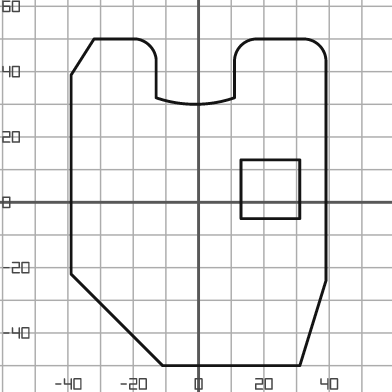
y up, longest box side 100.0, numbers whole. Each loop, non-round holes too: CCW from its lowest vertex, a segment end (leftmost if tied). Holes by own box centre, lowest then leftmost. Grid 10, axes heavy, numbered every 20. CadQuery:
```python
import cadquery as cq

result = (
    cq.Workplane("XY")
    .moveTo(-11.0, -50.0)
    .lineTo(31.0, -50.0)
    .lineTo(39.0, -24.0)
    .lineTo(39.0, 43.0)
    .threePointArc((37.0, 48.0), (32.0, 50.0))
    .lineTo(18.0, 50.0)
    .threePointArc((13.0, 48.0), (11.0, 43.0))
    .lineTo(11.0, 32.0)
    .threePointArc((-1.0, 30.0), (-13.0, 32.0))
    .lineTo(-13.0, 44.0)
    .threePointArc((-15.0, 48.0), (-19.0, 50.0))
    .lineTo(-32.0, 50.0)
    .lineTo(-39.0, 39.0)
    .lineTo(-39.0, -22.0)
    .close()
    .moveTo(13.0, -5.0)
    .lineTo(31.0, -5.0)
    .lineTo(31.0, 13.0)
    .lineTo(13.0, 13.0)
    .close()
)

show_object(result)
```